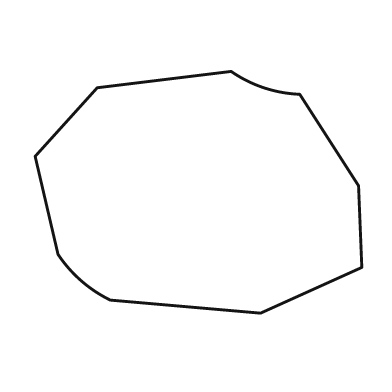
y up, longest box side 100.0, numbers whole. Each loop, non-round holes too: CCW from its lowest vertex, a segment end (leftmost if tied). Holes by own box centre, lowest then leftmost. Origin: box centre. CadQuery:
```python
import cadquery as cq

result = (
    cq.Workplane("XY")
    .moveTo(19.0, -37.0)
    .lineTo(50.0, -23.0)
    .lineTo(49.0, 2.0)
    .lineTo(31.0, 30.0)
    .threePointArc((20.0, 32.0), (10.0, 37.0))
    .lineTo(-31.0, 32.0)
    .lineTo(-50.0, 11.0)
    .lineTo(-43.0, -19.0)
    .threePointArc((-36.0, -27.0), (-27.0, -33.0))
    .close()
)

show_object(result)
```